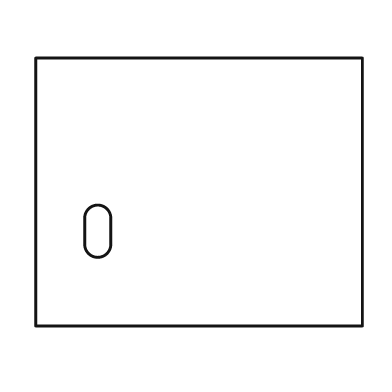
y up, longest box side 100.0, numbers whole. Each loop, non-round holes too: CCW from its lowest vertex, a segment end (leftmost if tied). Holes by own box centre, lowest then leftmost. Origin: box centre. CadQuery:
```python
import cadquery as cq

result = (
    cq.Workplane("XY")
    .moveTo(-50.0, -41.0)
    .lineTo(50.0, -41.0)
    .lineTo(50.0, 41.0)
    .lineTo(-50.0, 41.0)
    .close()
    .moveTo(-35.0, -16.0)
    .threePointArc((-31.0, -20.0), (-27.0, -16.0))
    .lineTo(-27.0, -8.0)
    .threePointArc((-31.0, -4.0), (-35.0, -8.0))
    .close()
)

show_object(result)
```